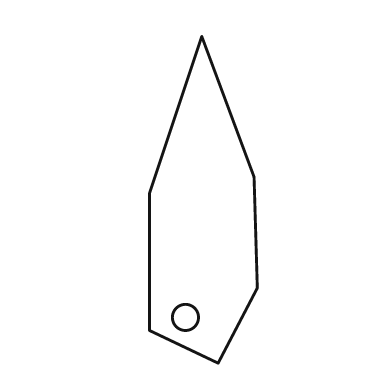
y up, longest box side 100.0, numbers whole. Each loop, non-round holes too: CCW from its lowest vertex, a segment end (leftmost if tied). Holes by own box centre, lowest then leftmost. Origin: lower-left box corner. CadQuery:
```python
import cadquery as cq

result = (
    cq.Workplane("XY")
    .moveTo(21.0, 0.0)
    .lineTo(33.0, 23.0)
    .lineTo(32.0, 57.0)
    .lineTo(16.0, 100.0)
    .lineTo(0.0, 52.0)
    .lineTo(0.0, 10.0)
    .close()
    .moveTo(11.0, 14.0)
    .circle(4.0)
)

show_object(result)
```